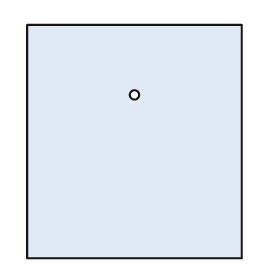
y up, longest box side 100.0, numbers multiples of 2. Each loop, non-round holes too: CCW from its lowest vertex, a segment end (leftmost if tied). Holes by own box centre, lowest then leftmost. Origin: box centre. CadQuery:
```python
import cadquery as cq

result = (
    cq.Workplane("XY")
    .moveTo(-46.0, -50.0)
    .lineTo(46.0, -50.0)
    .lineTo(46.0, 50.0)
    .lineTo(-46.0, 50.0)
    .close()
    .moveTo(0.0, 20.0)
    .circle(2.0)
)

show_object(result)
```